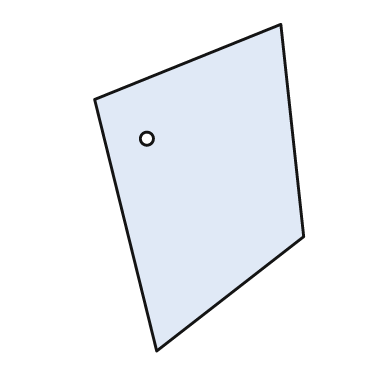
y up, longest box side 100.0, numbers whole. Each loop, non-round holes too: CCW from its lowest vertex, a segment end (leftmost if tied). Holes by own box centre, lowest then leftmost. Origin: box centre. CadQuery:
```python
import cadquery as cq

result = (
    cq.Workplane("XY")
    .moveTo(-13.0, -50.0)
    .lineTo(32.0, -15.0)
    .lineTo(25.0, 50.0)
    .lineTo(-32.0, 27.0)
    .close()
    .moveTo(-16.0, 15.0)
    .circle(2.0)
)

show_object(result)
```